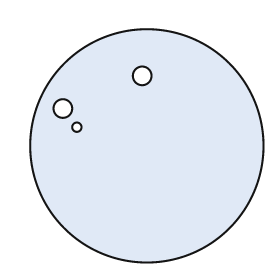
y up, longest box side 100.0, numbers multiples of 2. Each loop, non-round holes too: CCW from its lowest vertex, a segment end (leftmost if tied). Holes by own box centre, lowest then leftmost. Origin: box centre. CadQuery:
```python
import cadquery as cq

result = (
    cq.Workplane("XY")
    .moveTo(0.0, 0.0)
    .circle(50.0)
    .moveTo(-30.0, 8.0)
    .circle(2.0)
    .moveTo(-36.0, 16.0)
    .circle(4.0)
    .moveTo(-2.0, 30.0)
    .circle(4.0)
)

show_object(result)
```